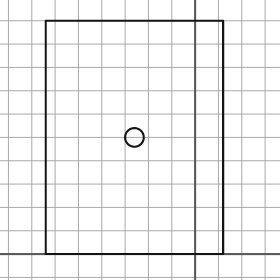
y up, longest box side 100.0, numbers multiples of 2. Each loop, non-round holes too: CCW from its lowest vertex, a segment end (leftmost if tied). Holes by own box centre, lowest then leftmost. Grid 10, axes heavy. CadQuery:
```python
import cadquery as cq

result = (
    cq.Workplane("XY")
    .moveTo(-64.0, 0.0)
    .lineTo(12.0, 0.0)
    .lineTo(12.0, 100.0)
    .lineTo(-64.0, 100.0)
    .close()
    .moveTo(-26.0, 50.0)
    .circle(4.0)
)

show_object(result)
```